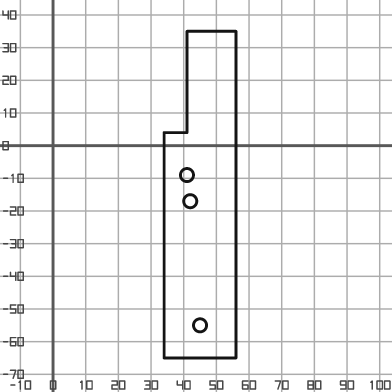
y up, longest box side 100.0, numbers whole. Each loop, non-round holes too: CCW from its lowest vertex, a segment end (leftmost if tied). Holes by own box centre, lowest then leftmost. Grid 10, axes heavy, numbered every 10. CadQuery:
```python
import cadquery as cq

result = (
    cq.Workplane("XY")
    .moveTo(34.0, -65.0)
    .lineTo(56.0, -65.0)
    .lineTo(56.0, 35.0)
    .lineTo(41.0, 35.0)
    .lineTo(41.0, 4.0)
    .lineTo(34.0, 4.0)
    .close()
    .moveTo(45.0, -55.0)
    .circle(2.0)
    .moveTo(42.0, -17.0)
    .circle(2.0)
    .moveTo(41.0, -9.0)
    .circle(2.0)
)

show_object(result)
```